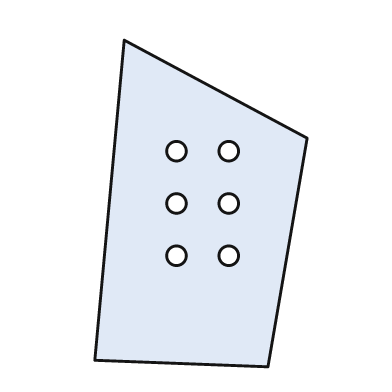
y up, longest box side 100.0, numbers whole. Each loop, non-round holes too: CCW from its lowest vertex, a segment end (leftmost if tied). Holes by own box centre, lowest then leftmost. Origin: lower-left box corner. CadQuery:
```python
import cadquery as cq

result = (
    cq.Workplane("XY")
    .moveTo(53.0, 0.0)
    .lineTo(65.0, 70.0)
    .lineTo(9.0, 100.0)
    .lineTo(0.0, 2.0)
    .close()
    .moveTo(25.0, 34.0)
    .circle(3.0)
    .moveTo(41.0, 34.0)
    .circle(3.0)
    .moveTo(25.0, 50.0)
    .circle(3.0)
    .moveTo(41.0, 50.0)
    .circle(3.0)
    .moveTo(25.0, 66.0)
    .circle(3.0)
    .moveTo(41.0, 66.0)
    .circle(3.0)
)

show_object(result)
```